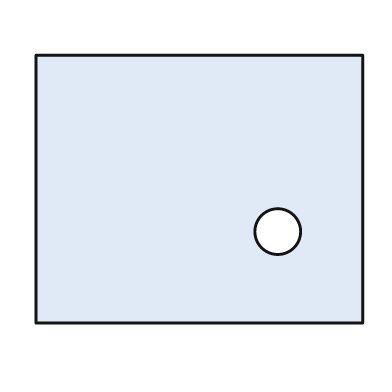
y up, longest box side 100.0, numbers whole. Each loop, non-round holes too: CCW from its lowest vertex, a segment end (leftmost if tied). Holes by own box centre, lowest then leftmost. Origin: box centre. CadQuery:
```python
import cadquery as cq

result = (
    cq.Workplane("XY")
    .moveTo(-50.0, -41.0)
    .lineTo(50.0, -41.0)
    .lineTo(50.0, 41.0)
    .lineTo(-50.0, 41.0)
    .close()
    .moveTo(24.0, -13.0)
    .circle(7.0)
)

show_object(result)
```